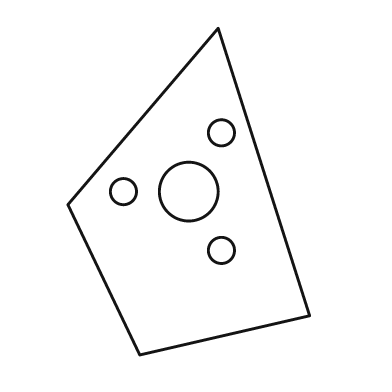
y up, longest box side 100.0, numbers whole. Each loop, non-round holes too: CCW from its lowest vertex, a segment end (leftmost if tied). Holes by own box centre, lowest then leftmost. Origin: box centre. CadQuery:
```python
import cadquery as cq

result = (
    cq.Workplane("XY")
    .moveTo(-15.0, -50.0)
    .lineTo(37.0, -38.0)
    .lineTo(9.0, 50.0)
    .lineTo(-37.0, -4.0)
    .close()
    .moveTo(10.0, -18.0)
    .circle(4.0)
    .moveTo(-20.0, 0.0)
    .circle(4.0)
    .moveTo(0.0, 0.0)
    .circle(9.0)
    .moveTo(10.0, 18.0)
    .circle(4.0)
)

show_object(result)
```